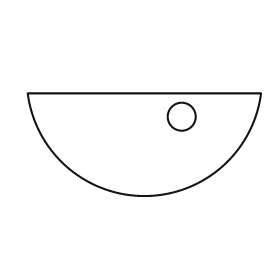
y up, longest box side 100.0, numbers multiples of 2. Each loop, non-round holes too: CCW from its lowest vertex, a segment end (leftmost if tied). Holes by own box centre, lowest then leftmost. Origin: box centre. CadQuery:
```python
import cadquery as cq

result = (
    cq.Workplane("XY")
    .moveTo(-50.0, 22.0)
    .threePointArc((0.0, -22.0), (50.0, 22.0))
    .close()
    .moveTo(16.0, 12.0)
    .circle(6.0)
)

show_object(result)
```